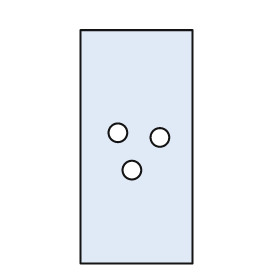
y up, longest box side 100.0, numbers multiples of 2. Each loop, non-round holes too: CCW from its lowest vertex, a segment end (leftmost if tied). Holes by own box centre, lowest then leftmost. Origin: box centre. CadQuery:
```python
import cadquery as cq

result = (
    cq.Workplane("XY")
    .moveTo(-24.0, -50.0)
    .lineTo(24.0, -50.0)
    .lineTo(24.0, 50.0)
    .lineTo(-24.0, 50.0)
    .close()
    .moveTo(-2.0, -10.0)
    .circle(4.0)
    .moveTo(10.0, 4.0)
    .circle(4.0)
    .moveTo(-8.0, 6.0)
    .circle(4.0)
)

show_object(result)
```